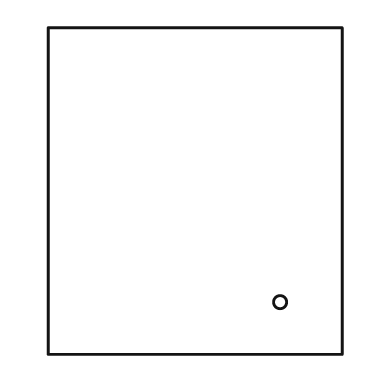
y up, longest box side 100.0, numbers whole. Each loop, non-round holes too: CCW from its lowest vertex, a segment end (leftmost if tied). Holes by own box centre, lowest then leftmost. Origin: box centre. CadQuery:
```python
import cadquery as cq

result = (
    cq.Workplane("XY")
    .moveTo(-45.0, -50.0)
    .lineTo(45.0, -50.0)
    .lineTo(45.0, 50.0)
    .lineTo(-45.0, 50.0)
    .close()
    .moveTo(26.0, -34.0)
    .circle(2.0)
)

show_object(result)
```